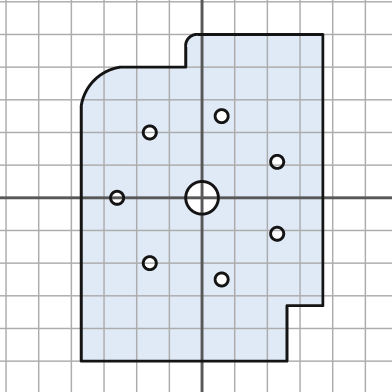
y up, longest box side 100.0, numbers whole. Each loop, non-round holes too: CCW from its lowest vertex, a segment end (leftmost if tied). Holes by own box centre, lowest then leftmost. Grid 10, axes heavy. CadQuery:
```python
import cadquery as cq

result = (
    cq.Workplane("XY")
    .moveTo(-37.0, -50.0)
    .lineTo(26.0, -50.0)
    .lineTo(26.0, -33.0)
    .lineTo(37.0, -33.0)
    .lineTo(37.0, 50.0)
    .lineTo(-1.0, 50.0)
    .threePointArc((-4.0, 49.0), (-5.0, 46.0))
    .lineTo(-5.0, 40.0)
    .lineTo(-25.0, 40.0)
    .threePointArc((-33.0, 36.0), (-37.0, 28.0))
    .close()
    .moveTo(6.0, -25.0)
    .circle(2.0)
    .moveTo(-16.0, -20.0)
    .circle(2.0)
    .moveTo(23.0, -11.0)
    .circle(2.0)
    .moveTo(-26.0, 0.0)
    .circle(2.0)
    .moveTo(0.0, 0.0)
    .circle(5.0)
    .moveTo(23.0, 11.0)
    .circle(2.0)
    .moveTo(-16.0, 20.0)
    .circle(2.0)
    .moveTo(6.0, 25.0)
    .circle(2.0)
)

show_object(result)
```